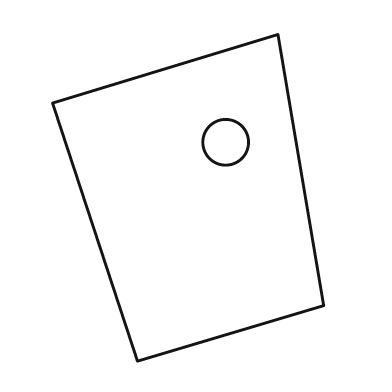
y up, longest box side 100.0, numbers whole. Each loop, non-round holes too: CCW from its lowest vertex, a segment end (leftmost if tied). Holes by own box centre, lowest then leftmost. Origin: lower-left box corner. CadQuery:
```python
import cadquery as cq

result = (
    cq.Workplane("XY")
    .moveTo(26.0, 0.0)
    .lineTo(83.0, 17.0)
    .lineTo(69.0, 100.0)
    .lineTo(0.0, 79.0)
    .close()
    .moveTo(53.0, 67.0)
    .circle(7.0)
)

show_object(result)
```